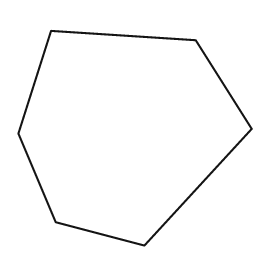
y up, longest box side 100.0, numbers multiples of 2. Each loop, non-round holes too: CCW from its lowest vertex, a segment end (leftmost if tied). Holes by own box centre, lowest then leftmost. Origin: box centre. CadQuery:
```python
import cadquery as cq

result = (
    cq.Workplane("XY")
    .moveTo(4.0, -46.0)
    .lineTo(50.0, 4.0)
    .lineTo(26.0, 42.0)
    .lineTo(-36.0, 46.0)
    .lineTo(-50.0, 2.0)
    .lineTo(-34.0, -36.0)
    .close()
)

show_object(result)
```